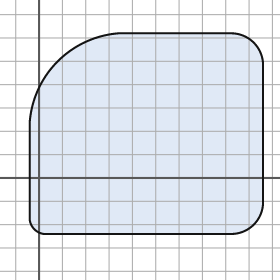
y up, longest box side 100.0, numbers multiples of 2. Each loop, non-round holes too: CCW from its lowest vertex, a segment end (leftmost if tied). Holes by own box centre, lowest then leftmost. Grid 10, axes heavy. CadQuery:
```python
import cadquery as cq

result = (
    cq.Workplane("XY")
    .moveTo(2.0, -24.0)
    .lineTo(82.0, -24.0)
    .threePointArc((92.0, -20.0), (96.0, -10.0))
    .lineTo(96.0, 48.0)
    .threePointArc((92.0, 58.0), (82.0, 62.0))
    .lineTo(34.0, 62.0)
    .threePointArc((8.0, 50.0), (-4.0, 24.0))
    .lineTo(-4.0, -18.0)
    .threePointArc((-2.0, -22.0), (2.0, -24.0))
    .close()
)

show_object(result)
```